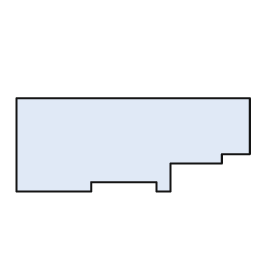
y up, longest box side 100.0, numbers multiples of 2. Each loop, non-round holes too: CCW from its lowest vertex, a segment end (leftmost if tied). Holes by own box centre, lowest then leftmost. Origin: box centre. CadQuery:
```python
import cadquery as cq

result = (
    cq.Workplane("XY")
    .moveTo(-50.0, -20.0)
    .lineTo(-18.0, -20.0)
    .lineTo(-18.0, -16.0)
    .lineTo(10.0, -16.0)
    .lineTo(10.0, -20.0)
    .lineTo(16.0, -20.0)
    .lineTo(16.0, -8.0)
    .lineTo(38.0, -8.0)
    .lineTo(38.0, -4.0)
    .lineTo(50.0, -4.0)
    .lineTo(50.0, 20.0)
    .lineTo(-50.0, 20.0)
    .close()
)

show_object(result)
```